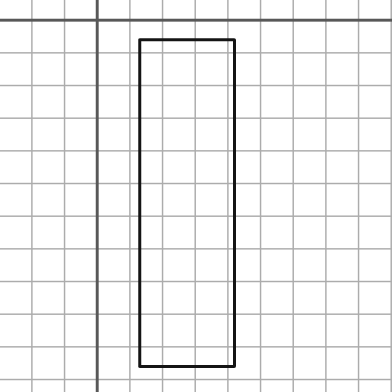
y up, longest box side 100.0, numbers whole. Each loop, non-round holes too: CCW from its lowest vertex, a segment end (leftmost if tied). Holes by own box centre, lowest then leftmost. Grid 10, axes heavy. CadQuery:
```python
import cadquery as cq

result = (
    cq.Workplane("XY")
    .moveTo(13.0, -106.0)
    .lineTo(42.0, -106.0)
    .lineTo(42.0, -6.0)
    .lineTo(13.0, -6.0)
    .close()
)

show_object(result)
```